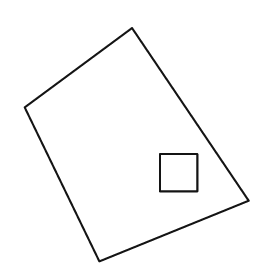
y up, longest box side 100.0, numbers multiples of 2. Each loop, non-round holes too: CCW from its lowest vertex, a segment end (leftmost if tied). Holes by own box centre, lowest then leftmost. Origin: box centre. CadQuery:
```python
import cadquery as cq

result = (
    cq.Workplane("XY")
    .moveTo(-16.0, -50.0)
    .lineTo(48.0, -24.0)
    .lineTo(-2.0, 50.0)
    .lineTo(-48.0, 16.0)
    .close()
    .moveTo(10.0, -20.0)
    .lineTo(26.0, -20.0)
    .lineTo(26.0, -4.0)
    .lineTo(10.0, -4.0)
    .close()
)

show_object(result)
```